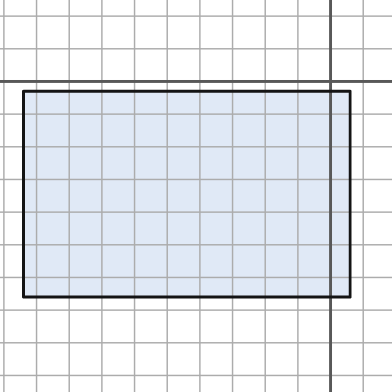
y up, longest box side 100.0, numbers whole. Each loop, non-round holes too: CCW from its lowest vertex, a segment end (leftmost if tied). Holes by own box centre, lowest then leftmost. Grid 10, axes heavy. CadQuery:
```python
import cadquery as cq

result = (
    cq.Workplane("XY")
    .moveTo(-94.0, -66.0)
    .lineTo(6.0, -66.0)
    .lineTo(6.0, -3.0)
    .lineTo(-94.0, -3.0)
    .close()
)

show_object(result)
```